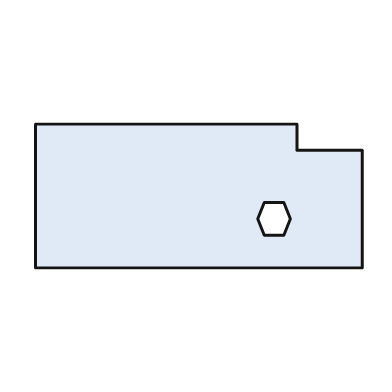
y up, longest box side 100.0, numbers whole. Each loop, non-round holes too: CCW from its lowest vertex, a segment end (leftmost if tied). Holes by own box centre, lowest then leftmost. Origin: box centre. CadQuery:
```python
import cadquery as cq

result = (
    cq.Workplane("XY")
    .moveTo(-50.0, -22.0)
    .lineTo(50.0, -22.0)
    .lineTo(50.0, 14.0)
    .lineTo(30.0, 14.0)
    .lineTo(30.0, 22.0)
    .lineTo(-50.0, 22.0)
    .close()
    .moveTo(20.0, -12.0)
    .lineTo(26.0, -12.0)
    .lineTo(28.0, -7.0)
    .lineTo(26.0, -2.0)
    .lineTo(20.0, -2.0)
    .lineTo(18.0, -7.0)
    .close()
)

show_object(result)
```